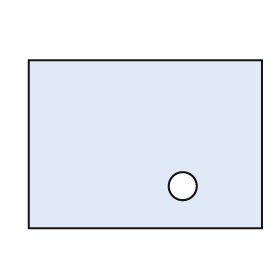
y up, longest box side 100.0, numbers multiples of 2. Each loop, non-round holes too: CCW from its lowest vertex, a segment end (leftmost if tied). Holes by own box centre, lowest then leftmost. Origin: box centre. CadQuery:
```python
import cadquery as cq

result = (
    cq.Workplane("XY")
    .moveTo(-50.0, -36.0)
    .lineTo(50.0, -36.0)
    .lineTo(50.0, 36.0)
    .lineTo(-50.0, 36.0)
    .close()
    .moveTo(16.0, -18.0)
    .circle(6.0)
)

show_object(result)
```